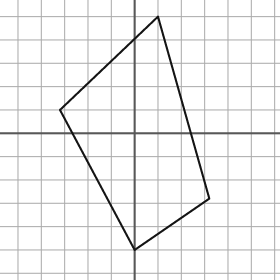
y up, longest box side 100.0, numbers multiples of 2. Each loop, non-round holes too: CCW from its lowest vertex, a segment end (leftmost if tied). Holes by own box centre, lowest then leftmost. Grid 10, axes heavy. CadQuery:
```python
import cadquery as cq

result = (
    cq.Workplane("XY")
    .moveTo(0.0, -50.0)
    .lineTo(32.0, -28.0)
    .lineTo(10.0, 50.0)
    .lineTo(-32.0, 10.0)
    .close()
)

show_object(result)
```